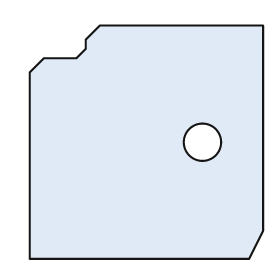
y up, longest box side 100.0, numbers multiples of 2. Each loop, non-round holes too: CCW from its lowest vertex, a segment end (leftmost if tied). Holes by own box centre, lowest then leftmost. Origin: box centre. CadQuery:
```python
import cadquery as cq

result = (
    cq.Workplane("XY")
    .moveTo(-50.0, -50.0)
    .lineTo(44.0, -50.0)
    .lineTo(50.0, -38.0)
    .lineTo(50.0, 50.0)
    .lineTo(-20.0, 50.0)
    .lineTo(-26.0, 44.0)
    .lineTo(-26.0, 40.0)
    .lineTo(-30.0, 36.0)
    .lineTo(-44.0, 36.0)
    .lineTo(-50.0, 30.0)
    .close()
    .moveTo(24.0, 0.0)
    .circle(8.0)
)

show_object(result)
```